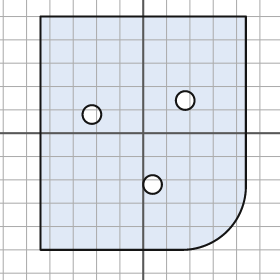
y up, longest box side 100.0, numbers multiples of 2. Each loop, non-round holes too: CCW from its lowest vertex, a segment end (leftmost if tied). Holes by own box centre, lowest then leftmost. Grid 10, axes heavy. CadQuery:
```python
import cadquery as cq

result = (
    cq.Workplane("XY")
    .moveTo(-44.0, -50.0)
    .lineTo(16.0, -50.0)
    .threePointArc((36.0, -42.0), (44.0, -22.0))
    .lineTo(44.0, 50.0)
    .lineTo(-44.0, 50.0)
    .close()
    .moveTo(4.0, -22.0)
    .circle(4.0)
    .moveTo(-22.0, 8.0)
    .circle(4.0)
    .moveTo(18.0, 14.0)
    .circle(4.0)
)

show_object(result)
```